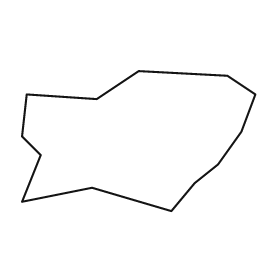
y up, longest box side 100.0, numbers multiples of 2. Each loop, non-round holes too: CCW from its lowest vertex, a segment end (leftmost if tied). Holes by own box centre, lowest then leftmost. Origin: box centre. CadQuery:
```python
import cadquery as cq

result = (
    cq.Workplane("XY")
    .moveTo(14.0, -30.0)
    .lineTo(24.0, -18.0)
    .lineTo(34.0, -10.0)
    .lineTo(44.0, 4.0)
    .lineTo(50.0, 20.0)
    .lineTo(38.0, 28.0)
    .lineTo(0.0, 30.0)
    .lineTo(-18.0, 18.0)
    .lineTo(-48.0, 20.0)
    .lineTo(-50.0, 2.0)
    .lineTo(-42.0, -6.0)
    .lineTo(-50.0, -26.0)
    .lineTo(-20.0, -20.0)
    .close()
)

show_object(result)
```